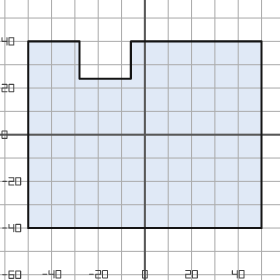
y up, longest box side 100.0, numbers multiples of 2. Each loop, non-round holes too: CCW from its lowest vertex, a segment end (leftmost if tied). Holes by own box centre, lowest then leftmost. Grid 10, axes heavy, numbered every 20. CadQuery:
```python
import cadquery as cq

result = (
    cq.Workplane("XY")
    .moveTo(-50.0, -40.0)
    .lineTo(50.0, -40.0)
    .lineTo(50.0, 40.0)
    .lineTo(-6.0, 40.0)
    .lineTo(-6.0, 24.0)
    .lineTo(-28.0, 24.0)
    .lineTo(-28.0, 40.0)
    .lineTo(-50.0, 40.0)
    .close()
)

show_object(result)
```